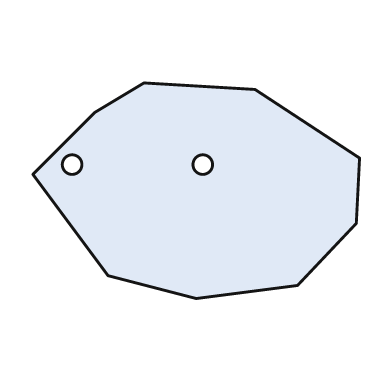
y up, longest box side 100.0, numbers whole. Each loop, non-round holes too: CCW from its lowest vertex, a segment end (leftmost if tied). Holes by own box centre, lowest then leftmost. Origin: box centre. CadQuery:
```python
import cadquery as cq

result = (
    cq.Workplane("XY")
    .moveTo(0.0, -33.0)
    .lineTo(31.0, -29.0)
    .lineTo(49.0, -10.0)
    .lineTo(50.0, 10.0)
    .lineTo(18.0, 31.0)
    .lineTo(-16.0, 33.0)
    .lineTo(-31.0, 24.0)
    .lineTo(-50.0, 5.0)
    .lineTo(-27.0, -26.0)
    .close()
    .moveTo(-38.0, 8.0)
    .circle(3.0)
    .moveTo(2.0, 8.0)
    .circle(3.0)
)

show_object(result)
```